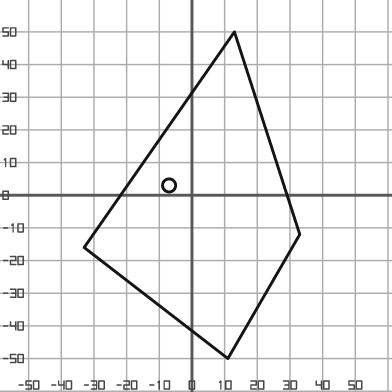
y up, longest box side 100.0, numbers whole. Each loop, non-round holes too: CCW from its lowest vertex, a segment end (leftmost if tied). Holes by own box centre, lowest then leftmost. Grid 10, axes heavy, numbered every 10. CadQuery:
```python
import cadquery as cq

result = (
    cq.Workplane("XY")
    .moveTo(11.0, -50.0)
    .lineTo(33.0, -12.0)
    .lineTo(13.0, 50.0)
    .lineTo(-33.0, -16.0)
    .close()
    .moveTo(-7.0, 3.0)
    .circle(2.0)
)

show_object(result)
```